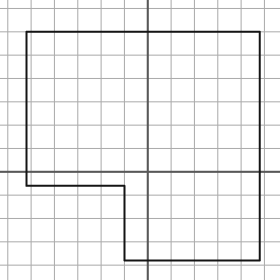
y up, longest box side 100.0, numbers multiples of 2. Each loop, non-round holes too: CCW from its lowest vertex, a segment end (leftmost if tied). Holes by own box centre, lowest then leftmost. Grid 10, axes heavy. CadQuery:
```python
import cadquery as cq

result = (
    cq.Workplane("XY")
    .moveTo(-10.0, -38.0)
    .lineTo(48.0, -38.0)
    .lineTo(48.0, 60.0)
    .lineTo(-52.0, 60.0)
    .lineTo(-52.0, -6.0)
    .lineTo(-10.0, -6.0)
    .close()
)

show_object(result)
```